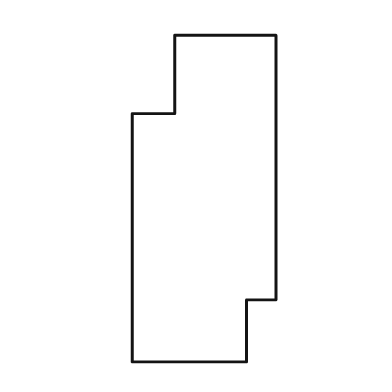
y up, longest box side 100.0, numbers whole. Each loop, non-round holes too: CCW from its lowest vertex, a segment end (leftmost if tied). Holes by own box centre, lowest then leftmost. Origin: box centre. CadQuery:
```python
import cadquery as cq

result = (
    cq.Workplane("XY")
    .moveTo(-22.0, -50.0)
    .lineTo(13.0, -50.0)
    .lineTo(13.0, -31.0)
    .lineTo(22.0, -31.0)
    .lineTo(22.0, 50.0)
    .lineTo(-9.0, 50.0)
    .lineTo(-9.0, 26.0)
    .lineTo(-22.0, 26.0)
    .close()
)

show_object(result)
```